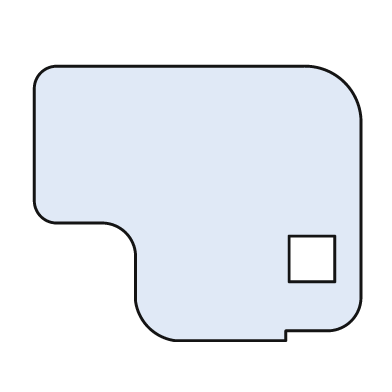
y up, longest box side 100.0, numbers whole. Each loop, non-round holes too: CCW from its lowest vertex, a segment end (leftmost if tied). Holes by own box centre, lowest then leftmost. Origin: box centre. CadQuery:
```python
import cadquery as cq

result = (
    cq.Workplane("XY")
    .moveTo(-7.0, -42.0)
    .lineTo(27.0, -42.0)
    .lineTo(27.0, -39.0)
    .lineTo(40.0, -39.0)
    .threePointArc((47.0, -36.0), (50.0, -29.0))
    .lineTo(50.0, 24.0)
    .threePointArc((45.0, 37.0), (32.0, 42.0))
    .lineTo(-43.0, 42.0)
    .threePointArc((-48.0, 40.0), (-50.0, 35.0))
    .lineTo(-50.0, 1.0)
    .threePointArc((-48.0, -4.0), (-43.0, -6.0))
    .lineTo(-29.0, -6.0)
    .threePointArc((-22.0, -9.0), (-19.0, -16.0))
    .lineTo(-19.0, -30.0)
    .threePointArc((-15.0, -38.0), (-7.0, -42.0))
    .close()
    .moveTo(28.0, -24.0)
    .lineTo(42.0, -24.0)
    .lineTo(42.0, -10.0)
    .lineTo(28.0, -10.0)
    .close()
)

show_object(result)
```